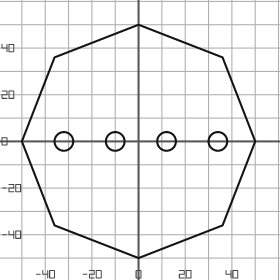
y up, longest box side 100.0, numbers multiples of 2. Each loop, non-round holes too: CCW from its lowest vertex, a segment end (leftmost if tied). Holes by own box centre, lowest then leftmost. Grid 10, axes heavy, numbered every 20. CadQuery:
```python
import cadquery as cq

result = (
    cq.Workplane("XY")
    .moveTo(0.0, -50.0)
    .lineTo(36.0, -36.0)
    .lineTo(50.0, 0.0)
    .lineTo(36.0, 36.0)
    .lineTo(0.0, 50.0)
    .lineTo(-36.0, 36.0)
    .lineTo(-50.0, 0.0)
    .lineTo(-36.0, -36.0)
    .close()
    .moveTo(-32.0, 0.0)
    .circle(4.0)
    .moveTo(-10.0, 0.0)
    .circle(4.0)
    .moveTo(12.0, 0.0)
    .circle(4.0)
    .moveTo(34.0, 0.0)
    .circle(4.0)
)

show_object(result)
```